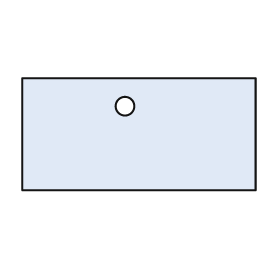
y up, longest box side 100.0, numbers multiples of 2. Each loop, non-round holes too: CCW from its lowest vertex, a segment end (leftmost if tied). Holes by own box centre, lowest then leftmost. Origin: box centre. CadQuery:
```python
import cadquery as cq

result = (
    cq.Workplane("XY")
    .moveTo(-50.0, -24.0)
    .lineTo(50.0, -24.0)
    .lineTo(50.0, 24.0)
    .lineTo(-50.0, 24.0)
    .close()
    .moveTo(-6.0, 12.0)
    .circle(4.0)
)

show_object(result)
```